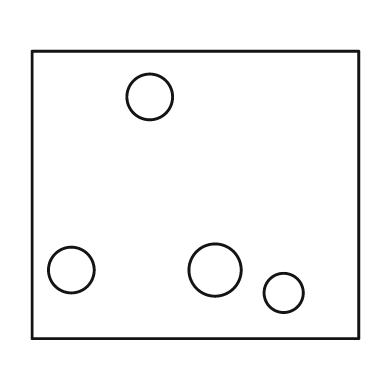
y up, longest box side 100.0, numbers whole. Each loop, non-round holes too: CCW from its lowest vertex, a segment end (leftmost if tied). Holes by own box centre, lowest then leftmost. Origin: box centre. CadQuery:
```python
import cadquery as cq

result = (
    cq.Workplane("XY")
    .moveTo(-50.0, -44.0)
    .lineTo(50.0, -44.0)
    .lineTo(50.0, 44.0)
    .lineTo(-50.0, 44.0)
    .close()
    .moveTo(27.0, -30.0)
    .circle(6.0)
    .moveTo(-38.0, -23.0)
    .circle(7.0)
    .moveTo(6.0, -23.0)
    .circle(8.0)
    .moveTo(-14.0, 30.0)
    .circle(7.0)
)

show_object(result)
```